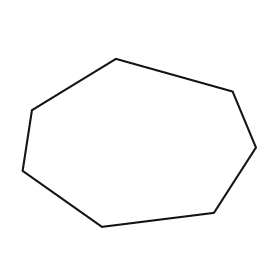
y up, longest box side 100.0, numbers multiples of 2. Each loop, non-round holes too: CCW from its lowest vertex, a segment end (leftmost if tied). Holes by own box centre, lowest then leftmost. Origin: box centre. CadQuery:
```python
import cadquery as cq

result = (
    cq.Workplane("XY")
    .moveTo(-16.0, -36.0)
    .lineTo(32.0, -30.0)
    .lineTo(50.0, -2.0)
    .lineTo(40.0, 22.0)
    .lineTo(-10.0, 36.0)
    .lineTo(-46.0, 14.0)
    .lineTo(-50.0, -12.0)
    .close()
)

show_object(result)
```